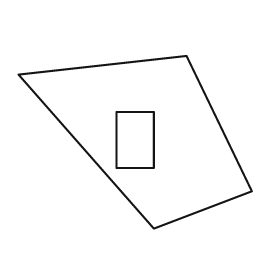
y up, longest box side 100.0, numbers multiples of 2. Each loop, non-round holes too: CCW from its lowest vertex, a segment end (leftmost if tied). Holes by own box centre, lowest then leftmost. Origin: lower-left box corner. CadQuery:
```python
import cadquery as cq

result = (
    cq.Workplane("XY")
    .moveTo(58.0, 0.0)
    .lineTo(100.0, 16.0)
    .lineTo(72.0, 74.0)
    .lineTo(0.0, 66.0)
    .close()
    .moveTo(42.0, 26.0)
    .lineTo(58.0, 26.0)
    .lineTo(58.0, 50.0)
    .lineTo(42.0, 50.0)
    .close()
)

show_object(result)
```